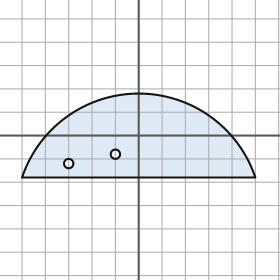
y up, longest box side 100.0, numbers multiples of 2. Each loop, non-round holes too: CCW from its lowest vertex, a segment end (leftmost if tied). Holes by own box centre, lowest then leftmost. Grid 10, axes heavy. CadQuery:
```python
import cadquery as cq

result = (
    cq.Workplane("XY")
    .moveTo(-50.0, -18.0)
    .lineTo(50.0, -18.0)
    .threePointArc((0.0, 18.0), (-50.0, -18.0))
    .close()
    .moveTo(-30.0, -12.0)
    .circle(2.0)
    .moveTo(-10.0, -8.0)
    .circle(2.0)
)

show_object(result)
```